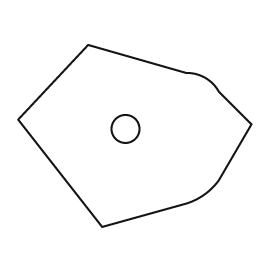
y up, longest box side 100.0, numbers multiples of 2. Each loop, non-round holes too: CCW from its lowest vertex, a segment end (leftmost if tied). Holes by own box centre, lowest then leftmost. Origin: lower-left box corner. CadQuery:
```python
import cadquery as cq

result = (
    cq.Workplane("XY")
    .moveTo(36.0, 0.0)
    .lineTo(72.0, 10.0)
    .threePointArc((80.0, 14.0), (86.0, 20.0))
    .lineTo(100.0, 44.0)
    .lineTo(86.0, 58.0)
    .threePointArc((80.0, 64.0), (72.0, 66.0))
    .lineTo(30.0, 78.0)
    .lineTo(0.0, 46.0)
    .close()
    .moveTo(46.0, 42.0)
    .circle(6.0)
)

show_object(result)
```